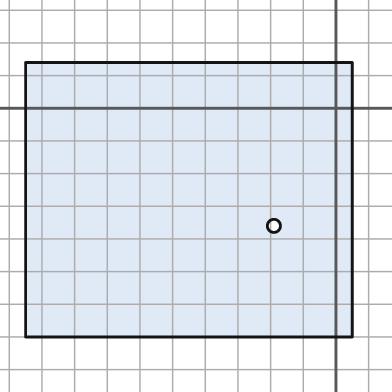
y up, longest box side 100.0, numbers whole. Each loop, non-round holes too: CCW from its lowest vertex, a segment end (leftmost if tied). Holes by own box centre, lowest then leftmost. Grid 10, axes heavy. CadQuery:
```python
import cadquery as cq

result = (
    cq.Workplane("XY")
    .moveTo(-95.0, -70.0)
    .lineTo(5.0, -70.0)
    .lineTo(5.0, 14.0)
    .lineTo(-95.0, 14.0)
    .close()
    .moveTo(-19.0, -36.0)
    .circle(2.0)
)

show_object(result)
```